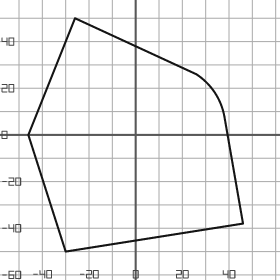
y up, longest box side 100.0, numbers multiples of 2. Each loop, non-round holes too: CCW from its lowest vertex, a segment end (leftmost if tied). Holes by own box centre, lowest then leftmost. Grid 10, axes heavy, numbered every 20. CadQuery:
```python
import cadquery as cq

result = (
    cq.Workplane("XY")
    .moveTo(-30.0, -50.0)
    .lineTo(46.0, -38.0)
    .lineTo(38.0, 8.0)
    .threePointArc((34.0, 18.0), (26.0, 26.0))
    .lineTo(-26.0, 50.0)
    .lineTo(-46.0, 0.0)
    .close()
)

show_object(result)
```